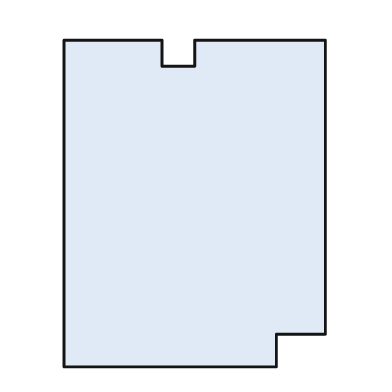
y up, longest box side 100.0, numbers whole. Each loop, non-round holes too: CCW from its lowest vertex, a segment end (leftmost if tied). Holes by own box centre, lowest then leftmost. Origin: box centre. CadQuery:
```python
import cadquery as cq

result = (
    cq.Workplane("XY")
    .moveTo(-40.0, -50.0)
    .lineTo(25.0, -50.0)
    .lineTo(25.0, -40.0)
    .lineTo(40.0, -40.0)
    .lineTo(40.0, 50.0)
    .lineTo(0.0, 50.0)
    .lineTo(0.0, 42.0)
    .lineTo(-10.0, 42.0)
    .lineTo(-10.0, 50.0)
    .lineTo(-40.0, 50.0)
    .close()
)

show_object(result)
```